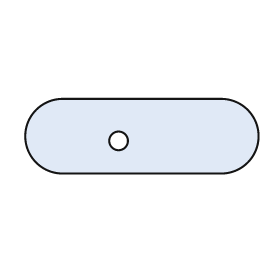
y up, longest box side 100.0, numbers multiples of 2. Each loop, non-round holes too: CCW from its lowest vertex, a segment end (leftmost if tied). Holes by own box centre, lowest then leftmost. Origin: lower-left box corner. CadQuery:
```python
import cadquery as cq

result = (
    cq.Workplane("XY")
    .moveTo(16.0, 0.0)
    .lineTo(84.0, 0.0)
    .threePointArc((100.0, 16.0), (84.0, 32.0))
    .lineTo(16.0, 32.0)
    .threePointArc((0.0, 16.0), (16.0, 0.0))
    .close()
    .moveTo(40.0, 14.0)
    .circle(4.0)
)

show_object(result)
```